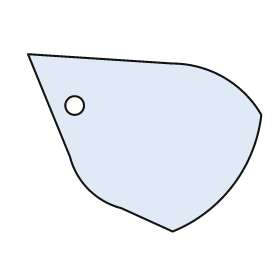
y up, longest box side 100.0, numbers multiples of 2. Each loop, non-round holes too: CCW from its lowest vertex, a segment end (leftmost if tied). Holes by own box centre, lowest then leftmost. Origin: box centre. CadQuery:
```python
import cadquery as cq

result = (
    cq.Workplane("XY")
    .moveTo(12.0, -38.0)
    .threePointArc((38.0, -18.0), (50.0, 12.0))
    .threePointArc((34.0, 28.0), (12.0, 34.0))
    .lineTo(-50.0, 38.0)
    .lineTo(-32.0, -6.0)
    .threePointArc((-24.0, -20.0), (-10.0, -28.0))
    .close()
    .moveTo(-30.0, 16.0)
    .circle(4.0)
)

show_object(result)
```